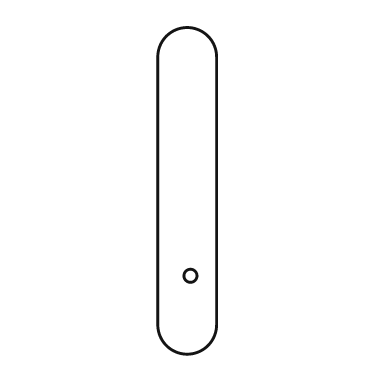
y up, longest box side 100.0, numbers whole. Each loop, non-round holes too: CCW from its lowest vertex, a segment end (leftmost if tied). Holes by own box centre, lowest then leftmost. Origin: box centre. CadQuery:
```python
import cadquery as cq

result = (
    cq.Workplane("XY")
    .moveTo(-9.0, -41.0)
    .threePointArc((0.0, -50.0), (9.0, -41.0))
    .lineTo(9.0, 41.0)
    .threePointArc((0.0, 50.0), (-9.0, 41.0))
    .close()
    .moveTo(1.0, -26.0)
    .circle(2.0)
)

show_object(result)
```